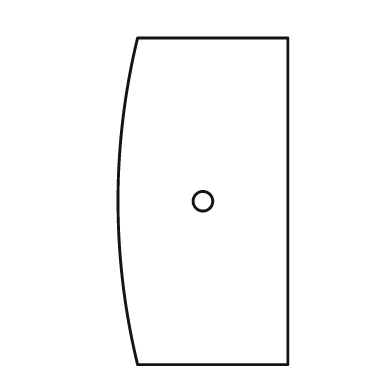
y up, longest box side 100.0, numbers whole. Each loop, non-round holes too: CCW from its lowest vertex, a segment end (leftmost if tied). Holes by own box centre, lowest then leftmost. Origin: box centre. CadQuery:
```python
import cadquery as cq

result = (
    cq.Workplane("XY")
    .moveTo(-20.0, -50.0)
    .lineTo(26.0, -50.0)
    .lineTo(26.0, 50.0)
    .lineTo(-20.0, 50.0)
    .threePointArc((-26.0, 0.0), (-20.0, -50.0))
    .close()
    .moveTo(0.0, 0.0)
    .circle(3.0)
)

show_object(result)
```